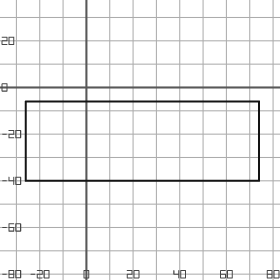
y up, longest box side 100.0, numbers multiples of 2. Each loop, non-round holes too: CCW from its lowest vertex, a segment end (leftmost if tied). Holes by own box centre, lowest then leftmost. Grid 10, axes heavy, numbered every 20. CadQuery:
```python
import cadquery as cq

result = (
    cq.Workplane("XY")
    .moveTo(-26.0, -40.0)
    .lineTo(74.0, -40.0)
    .lineTo(74.0, -6.0)
    .lineTo(-26.0, -6.0)
    .close()
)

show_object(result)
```